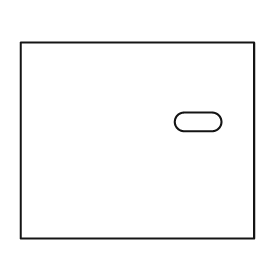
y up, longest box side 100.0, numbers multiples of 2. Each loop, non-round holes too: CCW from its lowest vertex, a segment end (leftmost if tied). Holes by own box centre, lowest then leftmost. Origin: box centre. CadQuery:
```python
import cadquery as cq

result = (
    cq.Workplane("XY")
    .moveTo(-50.0, -42.0)
    .lineTo(50.0, -42.0)
    .lineTo(50.0, 42.0)
    .lineTo(-50.0, 42.0)
    .close()
    .moveTo(20.0, 4.0)
    .lineTo(32.0, 4.0)
    .threePointArc((36.0, 8.0), (32.0, 12.0))
    .lineTo(20.0, 12.0)
    .threePointArc((16.0, 8.0), (20.0, 4.0))
    .close()
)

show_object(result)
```